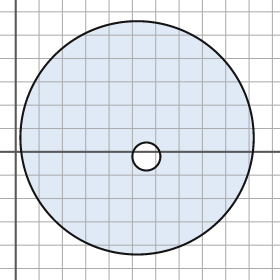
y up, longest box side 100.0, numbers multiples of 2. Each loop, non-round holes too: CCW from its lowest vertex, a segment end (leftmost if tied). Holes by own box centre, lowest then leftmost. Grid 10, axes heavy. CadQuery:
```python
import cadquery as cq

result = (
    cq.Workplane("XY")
    .moveTo(52.0, 6.0)
    .circle(50.0)
    .moveTo(56.0, -2.0)
    .circle(6.0)
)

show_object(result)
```